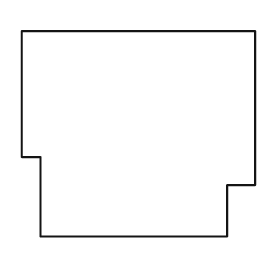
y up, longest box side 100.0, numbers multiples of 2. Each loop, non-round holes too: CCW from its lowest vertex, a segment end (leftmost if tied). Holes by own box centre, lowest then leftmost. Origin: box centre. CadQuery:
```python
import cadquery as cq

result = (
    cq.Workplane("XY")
    .moveTo(-42.0, -44.0)
    .lineTo(38.0, -44.0)
    .lineTo(38.0, -22.0)
    .lineTo(50.0, -22.0)
    .lineTo(50.0, 44.0)
    .lineTo(-50.0, 44.0)
    .lineTo(-50.0, -10.0)
    .lineTo(-42.0, -10.0)
    .close()
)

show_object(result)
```